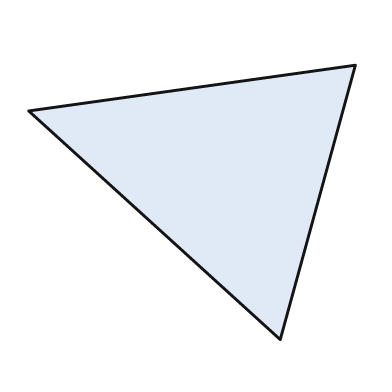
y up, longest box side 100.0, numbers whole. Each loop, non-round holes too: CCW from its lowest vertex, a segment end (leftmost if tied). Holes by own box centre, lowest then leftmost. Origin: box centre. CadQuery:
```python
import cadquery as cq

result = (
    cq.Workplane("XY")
    .moveTo(27.0, -42.0)
    .lineTo(50.0, 42.0)
    .lineTo(-50.0, 28.0)
    .close()
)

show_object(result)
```